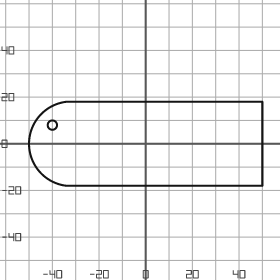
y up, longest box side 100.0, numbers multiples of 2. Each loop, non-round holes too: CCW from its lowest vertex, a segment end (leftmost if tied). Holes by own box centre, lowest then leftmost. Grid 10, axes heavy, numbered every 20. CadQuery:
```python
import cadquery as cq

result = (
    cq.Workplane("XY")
    .moveTo(-34.0, -18.0)
    .lineTo(50.0, -18.0)
    .lineTo(50.0, 18.0)
    .lineTo(-34.0, 18.0)
    .threePointArc((-50.0, 0.0), (-34.0, -18.0))
    .close()
    .moveTo(-40.0, 8.0)
    .circle(2.0)
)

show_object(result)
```